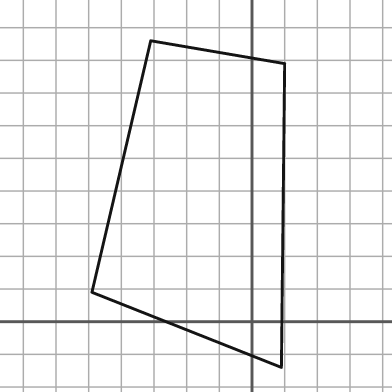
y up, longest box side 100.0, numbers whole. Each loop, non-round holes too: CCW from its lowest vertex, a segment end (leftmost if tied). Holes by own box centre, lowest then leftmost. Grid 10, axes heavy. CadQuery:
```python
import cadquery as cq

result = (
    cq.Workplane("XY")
    .moveTo(9.0, -14.0)
    .lineTo(10.0, 79.0)
    .lineTo(-31.0, 86.0)
    .lineTo(-49.0, 9.0)
    .close()
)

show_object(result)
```